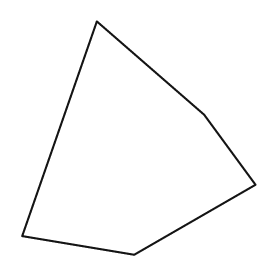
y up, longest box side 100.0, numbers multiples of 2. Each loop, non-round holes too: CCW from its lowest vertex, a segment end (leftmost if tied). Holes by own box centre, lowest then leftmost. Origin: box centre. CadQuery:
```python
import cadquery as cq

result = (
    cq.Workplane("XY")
    .moveTo(-2.0, -50.0)
    .lineTo(50.0, -20.0)
    .lineTo(28.0, 10.0)
    .lineTo(-18.0, 50.0)
    .lineTo(-50.0, -42.0)
    .close()
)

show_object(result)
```